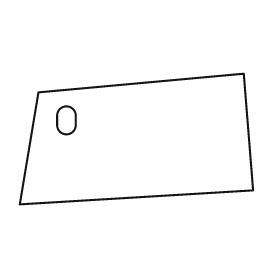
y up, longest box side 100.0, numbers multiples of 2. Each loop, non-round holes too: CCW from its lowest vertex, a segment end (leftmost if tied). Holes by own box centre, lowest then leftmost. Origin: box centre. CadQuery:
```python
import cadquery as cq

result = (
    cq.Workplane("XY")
    .moveTo(-50.0, -28.0)
    .lineTo(50.0, -22.0)
    .lineTo(46.0, 28.0)
    .lineTo(-42.0, 20.0)
    .close()
    .moveTo(-34.0, 6.0)
    .threePointArc((-30.0, 2.0), (-26.0, 6.0))
    .lineTo(-26.0, 10.0)
    .threePointArc((-30.0, 14.0), (-34.0, 10.0))
    .close()
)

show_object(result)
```